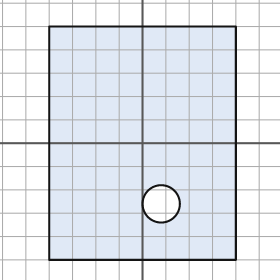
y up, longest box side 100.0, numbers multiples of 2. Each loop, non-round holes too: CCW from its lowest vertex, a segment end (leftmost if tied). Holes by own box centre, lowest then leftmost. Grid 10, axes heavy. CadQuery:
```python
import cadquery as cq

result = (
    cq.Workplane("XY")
    .moveTo(-40.0, -50.0)
    .lineTo(40.0, -50.0)
    .lineTo(40.0, 50.0)
    .lineTo(-40.0, 50.0)
    .close()
    .moveTo(8.0, -26.0)
    .circle(8.0)
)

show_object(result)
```